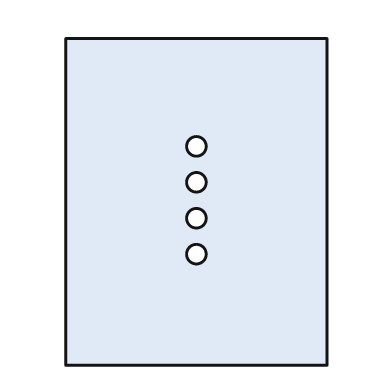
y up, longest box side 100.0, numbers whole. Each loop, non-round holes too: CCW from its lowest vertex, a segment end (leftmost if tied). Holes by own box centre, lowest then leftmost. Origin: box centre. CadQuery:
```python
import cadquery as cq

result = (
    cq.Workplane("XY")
    .moveTo(-40.0, -50.0)
    .lineTo(40.0, -50.0)
    .lineTo(40.0, 50.0)
    .lineTo(-40.0, 50.0)
    .close()
    .moveTo(0.0, -16.0)
    .circle(3.0)
    .moveTo(0.0, -5.0)
    .circle(3.0)
    .moveTo(0.0, 6.0)
    .circle(3.0)
    .moveTo(0.0, 17.0)
    .circle(3.0)
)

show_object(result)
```